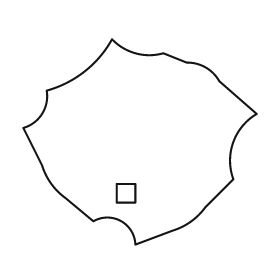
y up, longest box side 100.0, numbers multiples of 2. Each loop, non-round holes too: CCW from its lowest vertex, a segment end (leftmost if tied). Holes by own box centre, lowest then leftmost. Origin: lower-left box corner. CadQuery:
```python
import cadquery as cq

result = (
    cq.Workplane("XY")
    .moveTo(48.0, 0.0)
    .lineTo(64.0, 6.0)
    .threePointArc((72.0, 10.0), (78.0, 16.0))
    .lineTo(90.0, 28.0)
    .threePointArc((90.0, 44.0), (100.0, 56.0))
    .lineTo(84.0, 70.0)
    .threePointArc((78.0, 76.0), (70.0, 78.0))
    .lineTo(60.0, 82.0)
    .threePointArc((48.0, 82.0), (38.0, 88.0))
    .threePointArc((26.0, 74.0), (10.0, 66.0))
    .threePointArc((8.0, 56.0), (0.0, 50.0))
    .lineTo(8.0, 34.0)
    .threePointArc((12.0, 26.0), (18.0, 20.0))
    .lineTo(30.0, 10.0)
    .threePointArc((42.0, 10.0), (48.0, 0.0))
    .close()
    .moveTo(40.0, 18.0)
    .lineTo(48.0, 18.0)
    .lineTo(48.0, 26.0)
    .lineTo(40.0, 26.0)
    .close()
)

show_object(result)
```